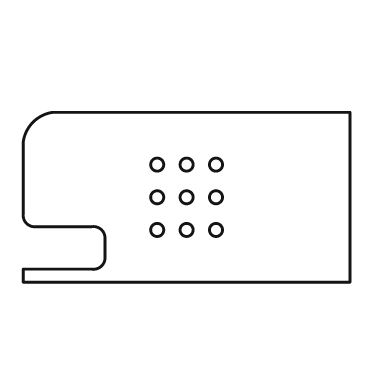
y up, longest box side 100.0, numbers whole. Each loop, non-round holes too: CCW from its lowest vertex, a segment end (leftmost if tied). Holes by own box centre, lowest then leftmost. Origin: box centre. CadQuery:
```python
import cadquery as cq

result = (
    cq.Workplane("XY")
    .moveTo(-50.0, -26.0)
    .lineTo(50.0, -26.0)
    .lineTo(50.0, 26.0)
    .lineTo(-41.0, 26.0)
    .threePointArc((-47.0, 23.0), (-50.0, 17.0))
    .lineTo(-50.0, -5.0)
    .threePointArc((-49.0, -8.0), (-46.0, -9.0))
    .lineTo(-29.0, -9.0)
    .threePointArc((-26.0, -10.0), (-25.0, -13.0))
    .lineTo(-25.0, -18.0)
    .threePointArc((-26.0, -21.0), (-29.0, -22.0))
    .lineTo(-50.0, -22.0)
    .close()
    .moveTo(-9.0, -10.0)
    .circle(2.0)
    .moveTo(0.0, -10.0)
    .circle(2.0)
    .moveTo(9.0, -10.0)
    .circle(2.0)
    .moveTo(-9.0, 0.0)
    .circle(2.0)
    .moveTo(0.0, 0.0)
    .circle(2.0)
    .moveTo(9.0, 0.0)
    .circle(2.0)
    .moveTo(-9.0, 10.0)
    .circle(2.0)
    .moveTo(0.0, 10.0)
    .circle(2.0)
    .moveTo(9.0, 10.0)
    .circle(2.0)
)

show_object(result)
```